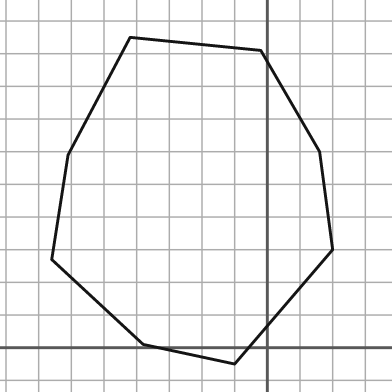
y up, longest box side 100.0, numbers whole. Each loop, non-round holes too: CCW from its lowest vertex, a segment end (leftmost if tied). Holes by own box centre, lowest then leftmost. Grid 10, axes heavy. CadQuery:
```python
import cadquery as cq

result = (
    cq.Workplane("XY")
    .moveTo(-10.0, -5.0)
    .lineTo(20.0, 30.0)
    .lineTo(16.0, 60.0)
    .lineTo(-2.0, 91.0)
    .lineTo(-42.0, 95.0)
    .lineTo(-61.0, 59.0)
    .lineTo(-66.0, 27.0)
    .lineTo(-38.0, 1.0)
    .close()
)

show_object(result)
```